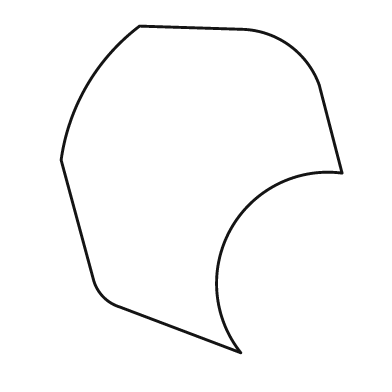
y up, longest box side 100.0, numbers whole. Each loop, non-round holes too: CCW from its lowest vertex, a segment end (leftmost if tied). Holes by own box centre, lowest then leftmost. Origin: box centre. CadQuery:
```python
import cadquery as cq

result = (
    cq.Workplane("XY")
    .moveTo(12.0, -50.0)
    .threePointArc((9.0, -12.0), (43.0, 5.0))
    .lineTo(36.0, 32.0)
    .threePointArc((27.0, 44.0), (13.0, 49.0))
    .lineTo(-19.0, 50.0)
    .threePointArc((-35.0, 32.0), (-43.0, 9.0))
    .lineTo(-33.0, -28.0)
    .threePointArc((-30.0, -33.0), (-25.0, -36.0))
    .close()
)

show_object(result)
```